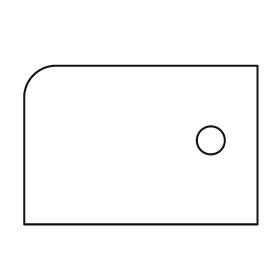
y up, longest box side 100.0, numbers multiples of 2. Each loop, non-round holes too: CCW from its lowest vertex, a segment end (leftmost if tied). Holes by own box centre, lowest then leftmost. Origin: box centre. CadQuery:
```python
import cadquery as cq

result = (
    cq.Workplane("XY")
    .moveTo(-50.0, -34.0)
    .lineTo(50.0, -34.0)
    .lineTo(50.0, 34.0)
    .lineTo(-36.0, 34.0)
    .threePointArc((-46.0, 30.0), (-50.0, 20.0))
    .close()
    .moveTo(30.0, 2.0)
    .circle(6.0)
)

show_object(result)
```